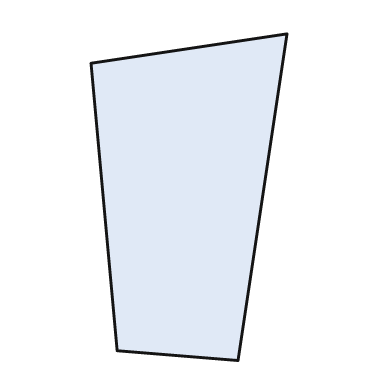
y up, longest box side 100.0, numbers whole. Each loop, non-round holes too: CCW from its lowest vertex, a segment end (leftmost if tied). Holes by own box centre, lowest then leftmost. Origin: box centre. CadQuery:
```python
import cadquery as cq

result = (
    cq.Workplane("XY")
    .moveTo(15.0, -50.0)
    .lineTo(30.0, 50.0)
    .lineTo(-30.0, 41.0)
    .lineTo(-22.0, -47.0)
    .close()
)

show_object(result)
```